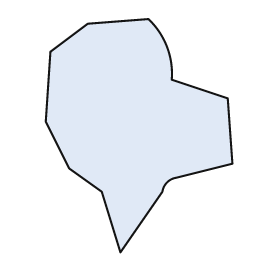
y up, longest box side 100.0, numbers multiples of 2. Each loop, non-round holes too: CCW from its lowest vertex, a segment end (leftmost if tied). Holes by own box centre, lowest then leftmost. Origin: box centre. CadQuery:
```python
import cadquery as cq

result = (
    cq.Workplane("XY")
    .moveTo(-8.0, -50.0)
    .lineTo(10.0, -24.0)
    .threePointArc((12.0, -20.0), (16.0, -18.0))
    .lineTo(40.0, -12.0)
    .lineTo(38.0, 16.0)
    .lineTo(14.0, 24.0)
    .threePointArc((12.0, 38.0), (4.0, 50.0))
    .lineTo(-22.0, 48.0)
    .lineTo(-38.0, 36.0)
    .lineTo(-40.0, 6.0)
    .lineTo(-30.0, -14.0)
    .lineTo(-16.0, -24.0)
    .close()
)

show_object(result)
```